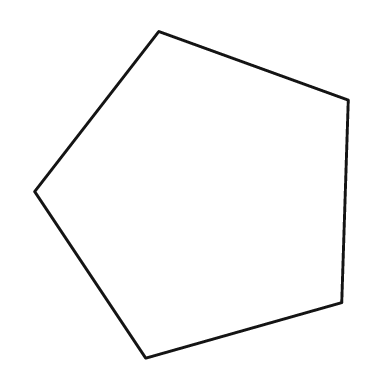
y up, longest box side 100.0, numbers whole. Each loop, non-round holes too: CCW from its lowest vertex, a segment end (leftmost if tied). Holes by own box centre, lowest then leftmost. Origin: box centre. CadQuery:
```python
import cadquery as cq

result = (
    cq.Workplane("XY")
    .moveTo(-14.0, -50.0)
    .lineTo(46.0, -33.0)
    .lineTo(48.0, 29.0)
    .lineTo(-10.0, 50.0)
    .lineTo(-48.0, 1.0)
    .close()
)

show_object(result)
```